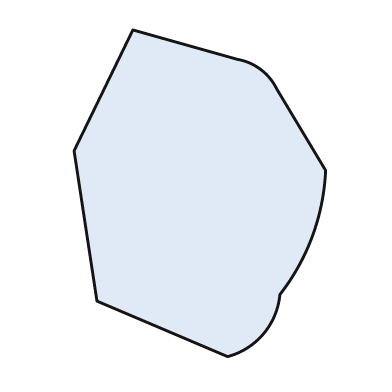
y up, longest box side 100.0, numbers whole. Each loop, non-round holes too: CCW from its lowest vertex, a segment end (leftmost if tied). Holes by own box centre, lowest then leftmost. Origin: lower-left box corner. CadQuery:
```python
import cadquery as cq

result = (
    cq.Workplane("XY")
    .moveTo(47.0, 0.0)
    .threePointArc((58.0, 7.0), (63.0, 19.0))
    .threePointArc((73.0, 37.0), (77.0, 57.0))
    .lineTo(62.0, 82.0)
    .threePointArc((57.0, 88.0), (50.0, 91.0))
    .lineTo(18.0, 100.0)
    .lineTo(0.0, 63.0)
    .lineTo(7.0, 17.0)
    .close()
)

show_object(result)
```